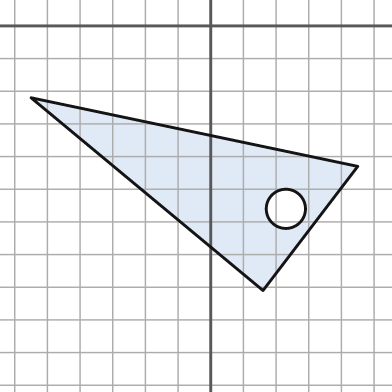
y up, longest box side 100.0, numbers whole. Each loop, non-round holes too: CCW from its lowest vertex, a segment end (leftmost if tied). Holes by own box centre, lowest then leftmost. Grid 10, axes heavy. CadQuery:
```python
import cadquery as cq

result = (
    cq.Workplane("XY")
    .moveTo(16.0, -81.0)
    .lineTo(45.0, -43.0)
    .lineTo(-55.0, -22.0)
    .close()
    .moveTo(23.0, -56.0)
    .circle(6.0)
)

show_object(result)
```